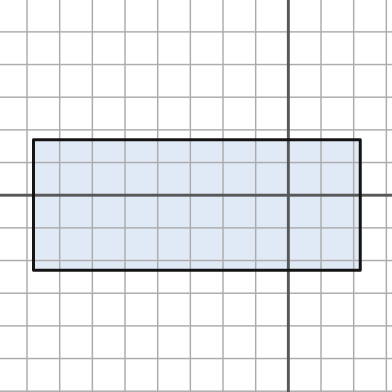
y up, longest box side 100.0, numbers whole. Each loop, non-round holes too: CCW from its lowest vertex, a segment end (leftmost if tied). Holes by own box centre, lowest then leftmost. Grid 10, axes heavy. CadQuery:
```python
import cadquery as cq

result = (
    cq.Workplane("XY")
    .moveTo(-78.0, -23.0)
    .lineTo(22.0, -23.0)
    .lineTo(22.0, 17.0)
    .lineTo(-78.0, 17.0)
    .close()
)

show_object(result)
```